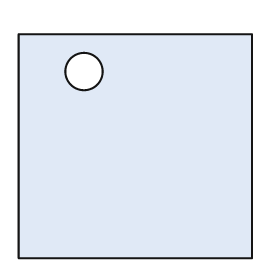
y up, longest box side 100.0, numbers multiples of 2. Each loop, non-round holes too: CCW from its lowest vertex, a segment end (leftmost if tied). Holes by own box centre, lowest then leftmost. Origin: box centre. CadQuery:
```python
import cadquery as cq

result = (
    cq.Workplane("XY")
    .moveTo(-50.0, -48.0)
    .lineTo(50.0, -48.0)
    .lineTo(50.0, 48.0)
    .lineTo(-50.0, 48.0)
    .close()
    .moveTo(-22.0, 32.0)
    .circle(8.0)
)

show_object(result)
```